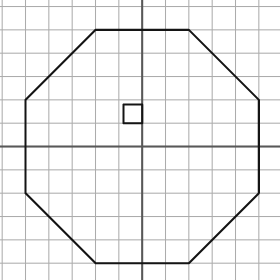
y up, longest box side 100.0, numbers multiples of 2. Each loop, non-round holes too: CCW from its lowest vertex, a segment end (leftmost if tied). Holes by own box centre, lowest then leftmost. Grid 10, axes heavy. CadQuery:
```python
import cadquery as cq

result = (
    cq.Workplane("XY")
    .moveTo(-20.0, -50.0)
    .lineTo(20.0, -50.0)
    .lineTo(50.0, -20.0)
    .lineTo(50.0, 20.0)
    .lineTo(20.0, 50.0)
    .lineTo(-20.0, 50.0)
    .lineTo(-50.0, 20.0)
    .lineTo(-50.0, -20.0)
    .close()
    .moveTo(-8.0, 10.0)
    .lineTo(0.0, 10.0)
    .lineTo(0.0, 18.0)
    .lineTo(-8.0, 18.0)
    .close()
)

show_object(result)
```